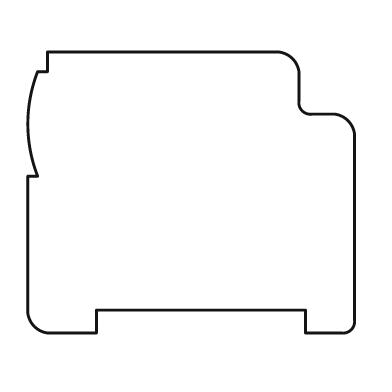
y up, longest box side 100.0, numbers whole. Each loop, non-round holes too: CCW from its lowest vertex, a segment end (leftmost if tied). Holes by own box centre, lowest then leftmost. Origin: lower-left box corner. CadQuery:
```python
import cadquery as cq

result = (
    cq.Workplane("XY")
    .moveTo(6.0, 0.0)
    .lineTo(21.0, 0.0)
    .lineTo(21.0, 7.0)
    .lineTo(85.0, 7.0)
    .lineTo(85.0, 0.0)
    .lineTo(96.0, 0.0)
    .threePointArc((99.0, 1.0), (100.0, 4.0))
    .lineTo(100.0, 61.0)
    .threePointArc((98.0, 65.0), (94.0, 67.0))
    .lineTo(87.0, 67.0)
    .threePointArc((84.0, 68.0), (83.0, 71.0))
    .lineTo(83.0, 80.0)
    .threePointArc((81.0, 84.0), (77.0, 86.0))
    .lineTo(6.0, 86.0)
    .lineTo(6.0, 80.0)
    .lineTo(3.0, 80.0)
    .threePointArc((0.0, 64.0), (3.0, 48.0))
    .lineTo(0.0, 48.0)
    .lineTo(0.0, 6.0)
    .threePointArc((2.0, 2.0), (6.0, 0.0))
    .close()
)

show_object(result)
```